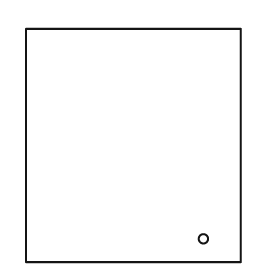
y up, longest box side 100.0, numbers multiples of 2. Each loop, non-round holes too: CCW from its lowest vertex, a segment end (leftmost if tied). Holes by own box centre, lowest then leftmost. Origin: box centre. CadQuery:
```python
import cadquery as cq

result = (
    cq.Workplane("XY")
    .moveTo(-46.0, -50.0)
    .lineTo(46.0, -50.0)
    .lineTo(46.0, 50.0)
    .lineTo(-46.0, 50.0)
    .close()
    .moveTo(30.0, -40.0)
    .circle(2.0)
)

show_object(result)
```